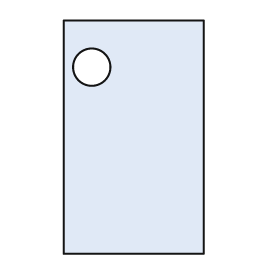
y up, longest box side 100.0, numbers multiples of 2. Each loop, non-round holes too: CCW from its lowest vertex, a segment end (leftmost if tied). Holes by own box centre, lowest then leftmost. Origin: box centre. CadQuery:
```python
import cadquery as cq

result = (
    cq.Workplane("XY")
    .moveTo(-30.0, -50.0)
    .lineTo(30.0, -50.0)
    .lineTo(30.0, 50.0)
    .lineTo(-30.0, 50.0)
    .close()
    .moveTo(-18.0, 30.0)
    .circle(8.0)
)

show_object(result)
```